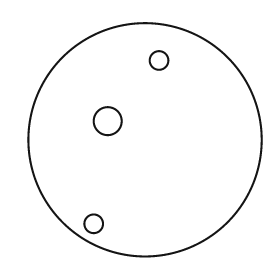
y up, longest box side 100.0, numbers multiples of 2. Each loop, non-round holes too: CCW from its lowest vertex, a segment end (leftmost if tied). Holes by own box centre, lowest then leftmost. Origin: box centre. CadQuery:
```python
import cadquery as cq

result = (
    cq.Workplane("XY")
    .moveTo(0.0, 0.0)
    .circle(50.0)
    .moveTo(-22.0, -36.0)
    .circle(4.0)
    .moveTo(-16.0, 8.0)
    .circle(6.0)
    .moveTo(6.0, 34.0)
    .circle(4.0)
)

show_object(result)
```